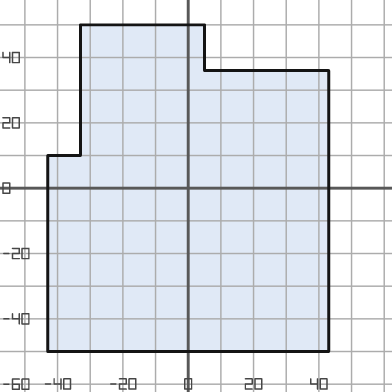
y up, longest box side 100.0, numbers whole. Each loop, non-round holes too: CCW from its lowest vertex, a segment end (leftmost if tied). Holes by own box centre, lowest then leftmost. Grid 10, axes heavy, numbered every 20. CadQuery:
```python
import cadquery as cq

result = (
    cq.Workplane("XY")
    .moveTo(-43.0, -50.0)
    .lineTo(43.0, -50.0)
    .lineTo(43.0, 36.0)
    .lineTo(5.0, 36.0)
    .lineTo(5.0, 50.0)
    .lineTo(-33.0, 50.0)
    .lineTo(-33.0, 10.0)
    .lineTo(-43.0, 10.0)
    .close()
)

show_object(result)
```